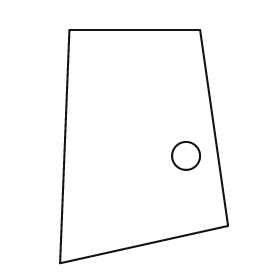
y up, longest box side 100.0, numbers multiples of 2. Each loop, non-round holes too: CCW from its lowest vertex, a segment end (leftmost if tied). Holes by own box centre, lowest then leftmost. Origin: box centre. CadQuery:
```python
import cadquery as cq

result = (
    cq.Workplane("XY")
    .moveTo(-36.0, -50.0)
    .lineTo(36.0, -34.0)
    .lineTo(24.0, 50.0)
    .lineTo(-32.0, 50.0)
    .close()
    .moveTo(18.0, -4.0)
    .circle(6.0)
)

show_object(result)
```